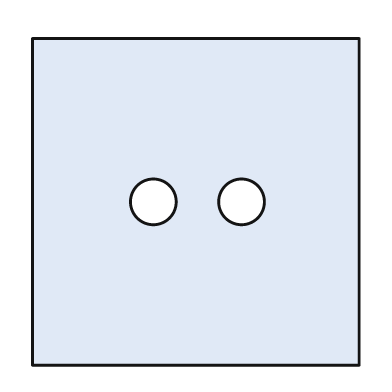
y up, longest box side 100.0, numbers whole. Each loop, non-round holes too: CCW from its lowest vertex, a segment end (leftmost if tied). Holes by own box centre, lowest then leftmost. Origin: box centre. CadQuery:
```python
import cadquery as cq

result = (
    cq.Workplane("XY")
    .moveTo(-50.0, -50.0)
    .lineTo(50.0, -50.0)
    .lineTo(50.0, 50.0)
    .lineTo(-50.0, 50.0)
    .close()
    .moveTo(-13.0, 0.0)
    .circle(7.0)
    .moveTo(14.0, 0.0)
    .circle(7.0)
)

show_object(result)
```